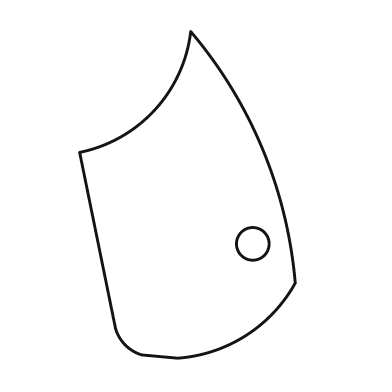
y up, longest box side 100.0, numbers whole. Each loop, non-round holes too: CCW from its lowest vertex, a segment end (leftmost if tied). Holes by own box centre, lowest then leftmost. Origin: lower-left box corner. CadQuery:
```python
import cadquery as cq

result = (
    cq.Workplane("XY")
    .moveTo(30.0, 0.0)
    .threePointArc((51.0, 7.0), (66.0, 23.0))
    .threePointArc((56.0, 64.0), (34.0, 100.0))
    .threePointArc((23.0, 76.0), (0.0, 63.0))
    .lineTo(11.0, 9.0)
    .threePointArc((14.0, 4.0), (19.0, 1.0))
    .close()
    .moveTo(53.0, 35.0)
    .circle(5.0)
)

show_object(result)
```